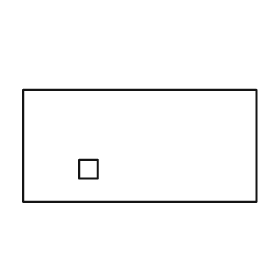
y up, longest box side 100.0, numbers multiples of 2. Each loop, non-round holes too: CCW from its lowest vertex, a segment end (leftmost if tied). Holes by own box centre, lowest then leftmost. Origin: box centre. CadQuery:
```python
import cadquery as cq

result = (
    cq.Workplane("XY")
    .moveTo(-50.0, -24.0)
    .lineTo(50.0, -24.0)
    .lineTo(50.0, 24.0)
    .lineTo(-50.0, 24.0)
    .close()
    .moveTo(-26.0, -14.0)
    .lineTo(-18.0, -14.0)
    .lineTo(-18.0, -6.0)
    .lineTo(-26.0, -6.0)
    .close()
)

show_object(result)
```